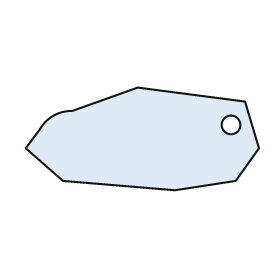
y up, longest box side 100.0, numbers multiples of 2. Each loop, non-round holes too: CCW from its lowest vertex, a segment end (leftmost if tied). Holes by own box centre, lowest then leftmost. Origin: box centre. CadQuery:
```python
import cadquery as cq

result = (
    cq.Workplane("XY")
    .moveTo(14.0, -22.0)
    .lineTo(40.0, -18.0)
    .lineTo(50.0, -4.0)
    .lineTo(44.0, 16.0)
    .lineTo(-2.0, 22.0)
    .lineTo(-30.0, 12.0)
    .threePointArc((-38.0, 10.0), (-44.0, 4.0))
    .lineTo(-50.0, -4.0)
    .lineTo(-34.0, -18.0)
    .close()
    .moveTo(38.0, 6.0)
    .circle(4.0)
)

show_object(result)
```